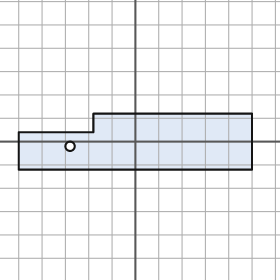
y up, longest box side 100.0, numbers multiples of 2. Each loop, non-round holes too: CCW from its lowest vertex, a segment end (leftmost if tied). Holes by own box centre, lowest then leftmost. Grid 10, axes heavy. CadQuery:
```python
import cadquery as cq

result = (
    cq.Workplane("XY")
    .moveTo(-50.0, -12.0)
    .lineTo(50.0, -12.0)
    .lineTo(50.0, 12.0)
    .lineTo(-18.0, 12.0)
    .lineTo(-18.0, 4.0)
    .lineTo(-50.0, 4.0)
    .close()
    .moveTo(-28.0, -2.0)
    .circle(2.0)
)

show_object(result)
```